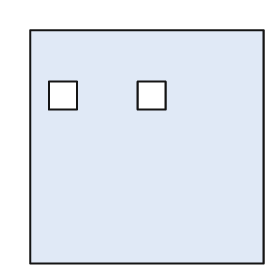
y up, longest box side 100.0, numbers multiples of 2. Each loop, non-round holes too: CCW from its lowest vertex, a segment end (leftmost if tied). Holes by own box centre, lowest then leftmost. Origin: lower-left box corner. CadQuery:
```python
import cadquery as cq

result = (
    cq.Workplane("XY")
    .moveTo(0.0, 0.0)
    .lineTo(100.0, 0.0)
    .lineTo(100.0, 100.0)
    .lineTo(0.0, 100.0)
    .close()
    .moveTo(8.0, 66.0)
    .lineTo(20.0, 66.0)
    .lineTo(20.0, 78.0)
    .lineTo(8.0, 78.0)
    .close()
    .moveTo(46.0, 66.0)
    .lineTo(58.0, 66.0)
    .lineTo(58.0, 78.0)
    .lineTo(46.0, 78.0)
    .close()
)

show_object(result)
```